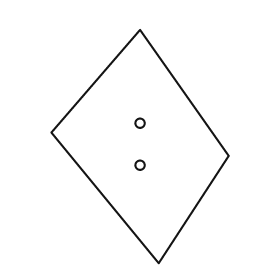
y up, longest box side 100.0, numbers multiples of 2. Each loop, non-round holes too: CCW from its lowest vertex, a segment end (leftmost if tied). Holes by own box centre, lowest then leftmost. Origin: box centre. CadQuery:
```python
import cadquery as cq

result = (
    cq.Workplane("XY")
    .moveTo(8.0, -50.0)
    .lineTo(38.0, -4.0)
    .lineTo(0.0, 50.0)
    .lineTo(-38.0, 6.0)
    .close()
    .moveTo(0.0, -8.0)
    .circle(2.0)
    .moveTo(0.0, 10.0)
    .circle(2.0)
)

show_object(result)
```